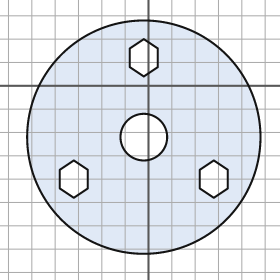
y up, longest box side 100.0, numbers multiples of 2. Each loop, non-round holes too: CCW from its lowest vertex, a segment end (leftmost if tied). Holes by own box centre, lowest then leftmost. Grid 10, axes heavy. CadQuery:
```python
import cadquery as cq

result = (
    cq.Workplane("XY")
    .moveTo(-2.0, -22.0)
    .circle(50.0)
    .moveTo(-32.0, -48.0)
    .lineTo(-26.0, -44.0)
    .lineTo(-26.0, -36.0)
    .lineTo(-32.0, -32.0)
    .lineTo(-38.0, -36.0)
    .lineTo(-38.0, -44.0)
    .close()
    .moveTo(28.0, -48.0)
    .lineTo(34.0, -44.0)
    .lineTo(34.0, -36.0)
    .lineTo(28.0, -32.0)
    .lineTo(22.0, -36.0)
    .lineTo(22.0, -44.0)
    .close()
    .moveTo(-2.0, -22.0)
    .circle(10.0)
    .moveTo(-2.0, 4.0)
    .lineTo(4.0, 8.0)
    .lineTo(4.0, 16.0)
    .lineTo(-2.0, 20.0)
    .lineTo(-8.0, 16.0)
    .lineTo(-8.0, 8.0)
    .close()
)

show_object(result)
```